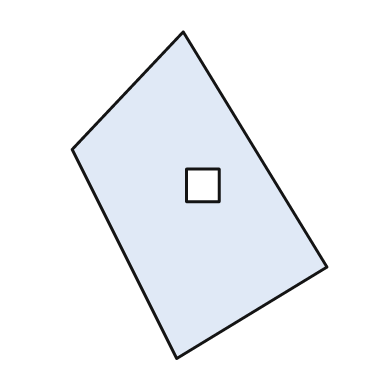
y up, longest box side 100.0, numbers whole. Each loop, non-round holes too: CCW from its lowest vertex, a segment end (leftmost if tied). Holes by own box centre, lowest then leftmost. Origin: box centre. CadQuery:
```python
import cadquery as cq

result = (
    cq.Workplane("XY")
    .moveTo(-7.0, -50.0)
    .lineTo(39.0, -22.0)
    .lineTo(-5.0, 50.0)
    .lineTo(-39.0, 14.0)
    .close()
    .moveTo(-4.0, -2.0)
    .lineTo(6.0, -2.0)
    .lineTo(6.0, 8.0)
    .lineTo(-4.0, 8.0)
    .close()
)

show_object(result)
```